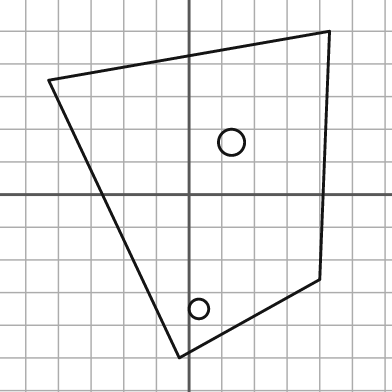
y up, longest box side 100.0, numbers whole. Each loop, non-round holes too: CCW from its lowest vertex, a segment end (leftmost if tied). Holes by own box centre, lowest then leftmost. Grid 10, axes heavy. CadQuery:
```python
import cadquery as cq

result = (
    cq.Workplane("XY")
    .moveTo(-3.0, -50.0)
    .lineTo(40.0, -26.0)
    .lineTo(43.0, 50.0)
    .lineTo(-43.0, 35.0)
    .close()
    .moveTo(3.0, -35.0)
    .circle(3.0)
    .moveTo(13.0, 16.0)
    .circle(4.0)
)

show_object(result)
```